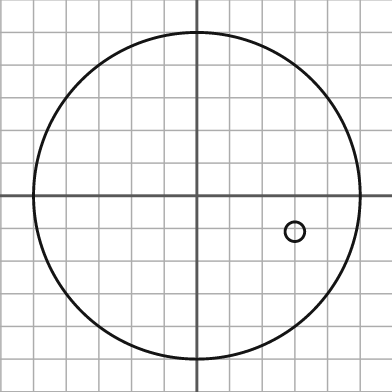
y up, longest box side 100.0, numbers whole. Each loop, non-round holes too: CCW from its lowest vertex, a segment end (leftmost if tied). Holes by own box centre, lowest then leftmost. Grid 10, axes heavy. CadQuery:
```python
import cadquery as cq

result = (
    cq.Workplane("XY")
    .moveTo(0.0, 0.0)
    .circle(50.0)
    .moveTo(30.0, -11.0)
    .circle(3.0)
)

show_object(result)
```